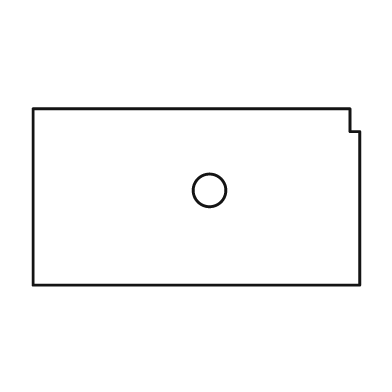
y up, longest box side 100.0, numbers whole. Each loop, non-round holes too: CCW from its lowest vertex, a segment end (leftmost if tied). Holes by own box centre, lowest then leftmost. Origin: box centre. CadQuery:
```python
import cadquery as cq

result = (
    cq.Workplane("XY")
    .moveTo(-50.0, -27.0)
    .lineTo(50.0, -27.0)
    .lineTo(50.0, 20.0)
    .lineTo(47.0, 20.0)
    .lineTo(47.0, 27.0)
    .lineTo(-50.0, 27.0)
    .close()
    .moveTo(4.0, 2.0)
    .circle(5.0)
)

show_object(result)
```